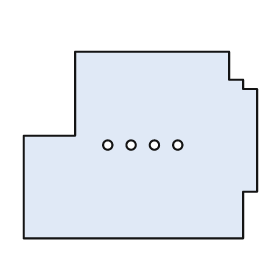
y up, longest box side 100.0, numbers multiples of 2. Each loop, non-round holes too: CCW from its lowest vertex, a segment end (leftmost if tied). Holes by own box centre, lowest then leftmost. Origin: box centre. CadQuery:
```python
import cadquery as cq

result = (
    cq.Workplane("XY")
    .moveTo(-50.0, -40.0)
    .lineTo(44.0, -40.0)
    .lineTo(44.0, -20.0)
    .lineTo(50.0, -20.0)
    .lineTo(50.0, 24.0)
    .lineTo(44.0, 24.0)
    .lineTo(44.0, 28.0)
    .lineTo(38.0, 28.0)
    .lineTo(38.0, 40.0)
    .lineTo(-28.0, 40.0)
    .lineTo(-28.0, 4.0)
    .lineTo(-50.0, 4.0)
    .close()
    .moveTo(-14.0, 0.0)
    .circle(2.0)
    .moveTo(-4.0, 0.0)
    .circle(2.0)
    .moveTo(6.0, 0.0)
    .circle(2.0)
    .moveTo(16.0, 0.0)
    .circle(2.0)
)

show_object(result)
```